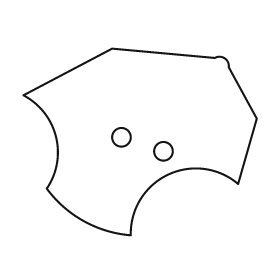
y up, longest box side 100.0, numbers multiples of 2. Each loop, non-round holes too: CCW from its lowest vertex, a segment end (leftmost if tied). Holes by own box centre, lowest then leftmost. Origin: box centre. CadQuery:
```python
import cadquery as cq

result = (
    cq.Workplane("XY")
    .moveTo(-4.0, -40.0)
    .threePointArc((12.0, -14.0), (42.0, -18.0))
    .lineTo(50.0, 10.0)
    .lineTo(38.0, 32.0)
    .threePointArc((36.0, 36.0), (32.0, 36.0))
    .lineTo(-12.0, 40.0)
    .lineTo(-50.0, 20.0)
    .threePointArc((-36.0, 2.0), (-40.0, -20.0))
    .threePointArc((-24.0, -34.0), (-4.0, -40.0))
    .close()
    .moveTo(10.0, -4.0)
    .circle(4.0)
    .moveTo(-8.0, 2.0)
    .circle(4.0)
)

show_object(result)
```